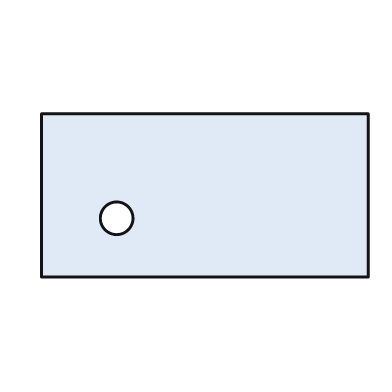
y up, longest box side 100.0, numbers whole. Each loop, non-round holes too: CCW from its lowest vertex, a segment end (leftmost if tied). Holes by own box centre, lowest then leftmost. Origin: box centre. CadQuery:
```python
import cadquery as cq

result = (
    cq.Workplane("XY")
    .moveTo(-50.0, -25.0)
    .lineTo(50.0, -25.0)
    .lineTo(50.0, 25.0)
    .lineTo(-50.0, 25.0)
    .close()
    .moveTo(-27.0, -7.0)
    .circle(5.0)
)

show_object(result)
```